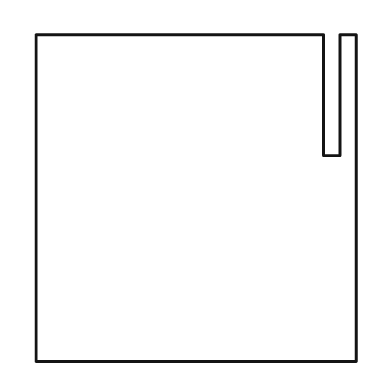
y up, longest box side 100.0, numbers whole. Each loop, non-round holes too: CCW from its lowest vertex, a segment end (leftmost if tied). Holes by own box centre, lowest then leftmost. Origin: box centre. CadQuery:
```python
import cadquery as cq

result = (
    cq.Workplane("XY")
    .moveTo(-49.0, -50.0)
    .lineTo(49.0, -50.0)
    .lineTo(49.0, 50.0)
    .lineTo(44.0, 50.0)
    .lineTo(44.0, 13.0)
    .lineTo(39.0, 13.0)
    .lineTo(39.0, 50.0)
    .lineTo(-49.0, 50.0)
    .close()
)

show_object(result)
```